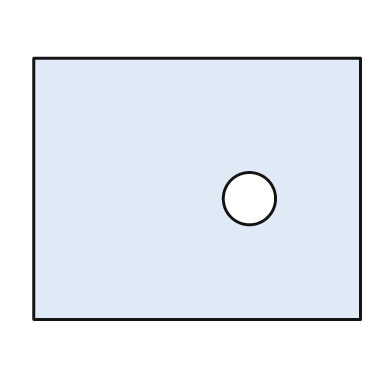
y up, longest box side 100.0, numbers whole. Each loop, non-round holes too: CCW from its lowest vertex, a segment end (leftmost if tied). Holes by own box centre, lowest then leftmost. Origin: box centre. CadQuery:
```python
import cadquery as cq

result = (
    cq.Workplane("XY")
    .moveTo(-50.0, -40.0)
    .lineTo(50.0, -40.0)
    .lineTo(50.0, 40.0)
    .lineTo(-50.0, 40.0)
    .close()
    .moveTo(16.0, -3.0)
    .circle(8.0)
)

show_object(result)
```